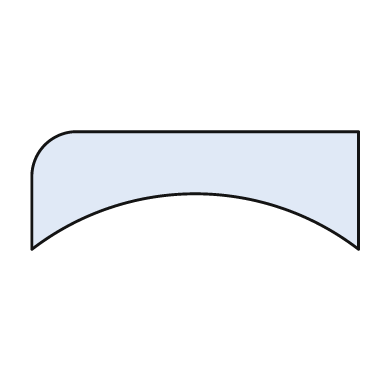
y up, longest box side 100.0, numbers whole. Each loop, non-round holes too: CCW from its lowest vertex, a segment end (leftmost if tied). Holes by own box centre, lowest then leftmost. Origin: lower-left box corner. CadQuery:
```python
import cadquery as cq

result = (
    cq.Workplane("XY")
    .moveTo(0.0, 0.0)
    .threePointArc((50.0, 17.0), (100.0, 0.0))
    .lineTo(100.0, 36.0)
    .lineTo(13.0, 36.0)
    .threePointArc((4.0, 32.0), (0.0, 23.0))
    .close()
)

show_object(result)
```